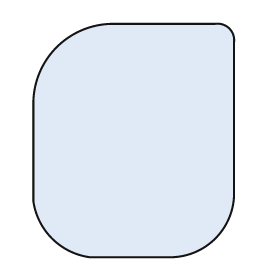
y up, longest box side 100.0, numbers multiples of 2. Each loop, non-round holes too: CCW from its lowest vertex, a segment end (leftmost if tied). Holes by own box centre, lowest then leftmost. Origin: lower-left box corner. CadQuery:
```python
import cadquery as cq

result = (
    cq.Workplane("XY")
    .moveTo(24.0, 0.0)
    .lineTo(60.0, 0.0)
    .threePointArc((78.0, 8.0), (86.0, 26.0))
    .lineTo(86.0, 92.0)
    .threePointArc((84.0, 98.0), (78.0, 100.0))
    .lineTo(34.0, 100.0)
    .threePointArc((10.0, 90.0), (0.0, 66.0))
    .lineTo(0.0, 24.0)
    .threePointArc((8.0, 8.0), (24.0, 0.0))
    .close()
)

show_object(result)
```